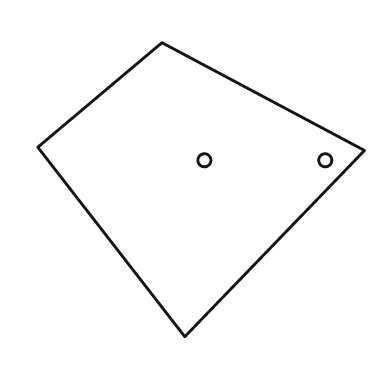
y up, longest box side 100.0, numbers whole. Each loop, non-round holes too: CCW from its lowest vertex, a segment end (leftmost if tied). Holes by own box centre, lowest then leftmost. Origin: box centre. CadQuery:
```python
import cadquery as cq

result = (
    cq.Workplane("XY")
    .moveTo(-5.0, -45.0)
    .lineTo(50.0, 12.0)
    .lineTo(-12.0, 45.0)
    .lineTo(-50.0, 13.0)
    .close()
    .moveTo(1.0, 9.0)
    .circle(2.0)
    .moveTo(38.0, 9.0)
    .circle(2.0)
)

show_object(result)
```